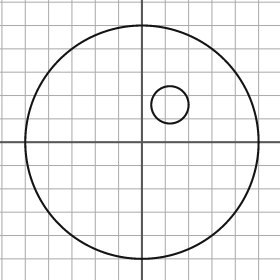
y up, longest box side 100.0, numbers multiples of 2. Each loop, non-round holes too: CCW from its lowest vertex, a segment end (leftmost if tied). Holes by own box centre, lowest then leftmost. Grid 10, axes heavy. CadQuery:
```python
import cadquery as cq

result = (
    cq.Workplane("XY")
    .moveTo(0.0, 0.0)
    .circle(50.0)
    .moveTo(12.0, 16.0)
    .circle(8.0)
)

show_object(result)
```